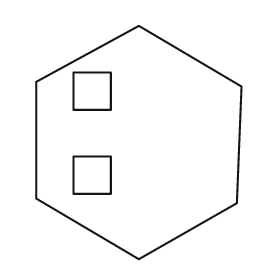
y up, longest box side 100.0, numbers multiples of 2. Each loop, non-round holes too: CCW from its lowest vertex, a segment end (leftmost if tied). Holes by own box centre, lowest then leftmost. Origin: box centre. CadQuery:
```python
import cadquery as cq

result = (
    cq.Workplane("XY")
    .moveTo(0.0, -50.0)
    .lineTo(42.0, -26.0)
    .lineTo(44.0, 24.0)
    .lineTo(0.0, 50.0)
    .lineTo(-44.0, 26.0)
    .lineTo(-44.0, -24.0)
    .close()
    .moveTo(-28.0, -22.0)
    .lineTo(-12.0, -22.0)
    .lineTo(-12.0, -6.0)
    .lineTo(-28.0, -6.0)
    .close()
    .moveTo(-28.0, 14.0)
    .lineTo(-12.0, 14.0)
    .lineTo(-12.0, 30.0)
    .lineTo(-28.0, 30.0)
    .close()
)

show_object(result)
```